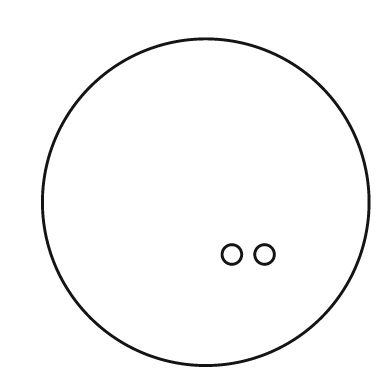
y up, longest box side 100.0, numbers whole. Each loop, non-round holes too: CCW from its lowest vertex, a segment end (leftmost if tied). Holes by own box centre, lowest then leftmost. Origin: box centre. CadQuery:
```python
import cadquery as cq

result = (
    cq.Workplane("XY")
    .moveTo(0.0, 0.0)
    .circle(50.0)
    .moveTo(8.0, -16.0)
    .circle(3.0)
    .moveTo(18.0, -16.0)
    .circle(3.0)
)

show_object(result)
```